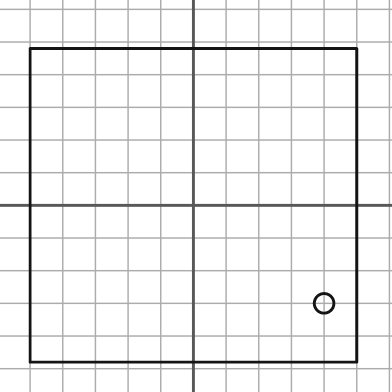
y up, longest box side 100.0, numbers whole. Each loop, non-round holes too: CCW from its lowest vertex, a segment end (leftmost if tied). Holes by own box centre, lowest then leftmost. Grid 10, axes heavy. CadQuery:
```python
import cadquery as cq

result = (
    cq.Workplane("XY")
    .moveTo(-50.0, -48.0)
    .lineTo(50.0, -48.0)
    .lineTo(50.0, 48.0)
    .lineTo(-50.0, 48.0)
    .close()
    .moveTo(40.0, -30.0)
    .circle(3.0)
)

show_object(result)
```